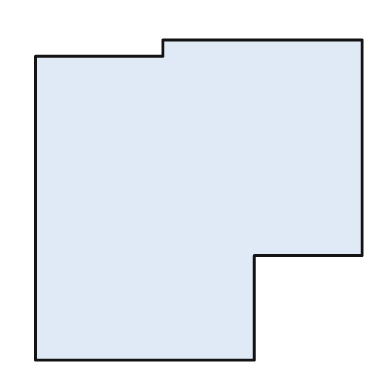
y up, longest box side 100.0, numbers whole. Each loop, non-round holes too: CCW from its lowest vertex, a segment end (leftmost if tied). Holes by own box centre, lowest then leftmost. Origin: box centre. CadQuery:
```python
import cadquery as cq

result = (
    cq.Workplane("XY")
    .moveTo(-50.0, -49.0)
    .lineTo(17.0, -49.0)
    .lineTo(17.0, -17.0)
    .lineTo(50.0, -17.0)
    .lineTo(50.0, 49.0)
    .lineTo(-11.0, 49.0)
    .lineTo(-11.0, 44.0)
    .lineTo(-50.0, 44.0)
    .close()
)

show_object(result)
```